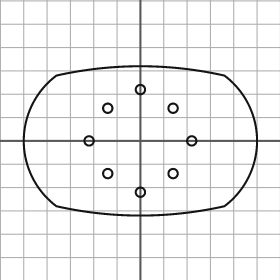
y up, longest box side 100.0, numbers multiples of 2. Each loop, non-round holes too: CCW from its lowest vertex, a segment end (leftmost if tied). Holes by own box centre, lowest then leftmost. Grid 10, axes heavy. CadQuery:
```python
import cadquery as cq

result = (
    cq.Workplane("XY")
    .moveTo(-36.0, -28.0)
    .threePointArc((0.0, -32.0), (36.0, -28.0))
    .threePointArc((50.0, 0.0), (36.0, 28.0))
    .threePointArc((0.0, 32.0), (-36.0, 28.0))
    .threePointArc((-50.0, 0.0), (-36.0, -28.0))
    .close()
    .moveTo(0.0, -22.0)
    .circle(2.0)
    .moveTo(-14.0, -14.0)
    .circle(2.0)
    .moveTo(14.0, -14.0)
    .circle(2.0)
    .moveTo(-22.0, 0.0)
    .circle(2.0)
    .moveTo(22.0, 0.0)
    .circle(2.0)
    .moveTo(-14.0, 14.0)
    .circle(2.0)
    .moveTo(14.0, 14.0)
    .circle(2.0)
    .moveTo(0.0, 22.0)
    .circle(2.0)
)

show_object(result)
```